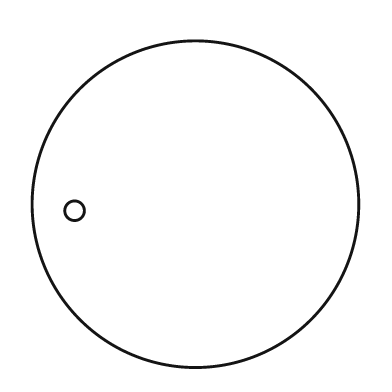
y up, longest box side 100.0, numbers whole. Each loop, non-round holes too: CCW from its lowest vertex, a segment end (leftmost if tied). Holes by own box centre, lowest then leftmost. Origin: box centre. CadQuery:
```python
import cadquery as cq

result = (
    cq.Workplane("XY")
    .moveTo(0.0, 0.0)
    .circle(50.0)
    .moveTo(-37.0, -2.0)
    .circle(3.0)
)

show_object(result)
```